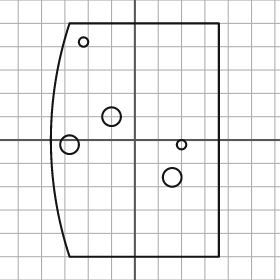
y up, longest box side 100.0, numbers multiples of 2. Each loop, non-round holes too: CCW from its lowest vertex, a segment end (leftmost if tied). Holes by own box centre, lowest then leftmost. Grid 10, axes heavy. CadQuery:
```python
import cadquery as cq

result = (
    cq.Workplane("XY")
    .moveTo(-28.0, -50.0)
    .lineTo(36.0, -50.0)
    .lineTo(36.0, 50.0)
    .lineTo(-28.0, 50.0)
    .threePointArc((-36.0, 0.0), (-28.0, -50.0))
    .close()
    .moveTo(16.0, -16.0)
    .circle(4.0)
    .moveTo(-28.0, -2.0)
    .circle(4.0)
    .moveTo(20.0, -2.0)
    .circle(2.0)
    .moveTo(-10.0, 10.0)
    .circle(4.0)
    .moveTo(-22.0, 42.0)
    .circle(2.0)
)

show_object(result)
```